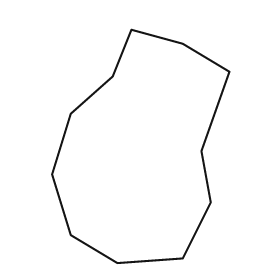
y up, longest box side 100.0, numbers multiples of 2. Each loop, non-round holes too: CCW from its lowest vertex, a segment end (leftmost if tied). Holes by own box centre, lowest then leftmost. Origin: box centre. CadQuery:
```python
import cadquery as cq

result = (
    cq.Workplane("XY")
    .moveTo(-10.0, -50.0)
    .lineTo(18.0, -48.0)
    .lineTo(30.0, -24.0)
    .lineTo(26.0, -2.0)
    .lineTo(38.0, 32.0)
    .lineTo(18.0, 44.0)
    .lineTo(-4.0, 50.0)
    .lineTo(-12.0, 30.0)
    .lineTo(-30.0, 14.0)
    .lineTo(-38.0, -12.0)
    .lineTo(-30.0, -38.0)
    .close()
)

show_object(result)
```